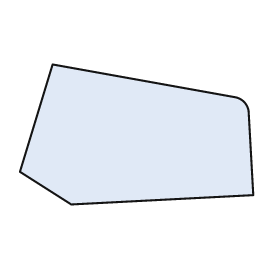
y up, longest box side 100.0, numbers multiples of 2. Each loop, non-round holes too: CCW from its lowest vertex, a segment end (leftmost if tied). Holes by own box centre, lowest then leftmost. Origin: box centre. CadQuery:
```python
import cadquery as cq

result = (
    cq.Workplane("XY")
    .moveTo(-28.0, -30.0)
    .lineTo(50.0, -26.0)
    .lineTo(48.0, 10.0)
    .threePointArc((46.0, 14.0), (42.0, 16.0))
    .lineTo(-36.0, 30.0)
    .lineTo(-50.0, -16.0)
    .close()
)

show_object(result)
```